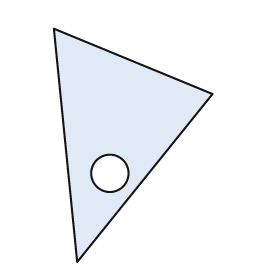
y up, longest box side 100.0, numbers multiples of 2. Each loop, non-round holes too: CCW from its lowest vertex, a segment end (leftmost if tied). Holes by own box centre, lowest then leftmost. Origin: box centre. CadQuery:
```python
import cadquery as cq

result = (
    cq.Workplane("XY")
    .moveTo(-24.0, -50.0)
    .lineTo(34.0, 22.0)
    .lineTo(-34.0, 50.0)
    .close()
    .moveTo(-10.0, -12.0)
    .circle(8.0)
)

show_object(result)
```